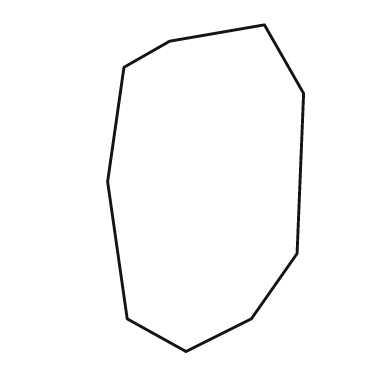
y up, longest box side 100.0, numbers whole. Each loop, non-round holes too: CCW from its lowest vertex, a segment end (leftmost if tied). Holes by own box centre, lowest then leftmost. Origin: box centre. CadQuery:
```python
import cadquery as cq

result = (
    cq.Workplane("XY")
    .moveTo(-6.0, -50.0)
    .lineTo(14.0, -40.0)
    .lineTo(28.0, -20.0)
    .lineTo(30.0, 29.0)
    .lineTo(18.0, 50.0)
    .lineTo(-11.0, 45.0)
    .lineTo(-25.0, 37.0)
    .lineTo(-30.0, 2.0)
    .lineTo(-24.0, -40.0)
    .close()
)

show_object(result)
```